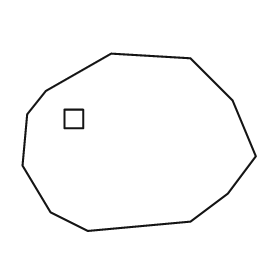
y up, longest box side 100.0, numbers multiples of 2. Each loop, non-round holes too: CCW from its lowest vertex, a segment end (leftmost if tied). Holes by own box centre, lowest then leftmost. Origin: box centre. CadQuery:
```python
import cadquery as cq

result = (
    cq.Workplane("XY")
    .moveTo(-22.0, -38.0)
    .lineTo(22.0, -34.0)
    .lineTo(38.0, -22.0)
    .lineTo(50.0, -6.0)
    .lineTo(40.0, 18.0)
    .lineTo(22.0, 36.0)
    .lineTo(-12.0, 38.0)
    .lineTo(-40.0, 22.0)
    .lineTo(-48.0, 12.0)
    .lineTo(-50.0, -10.0)
    .lineTo(-38.0, -30.0)
    .close()
    .moveTo(-32.0, 6.0)
    .lineTo(-24.0, 6.0)
    .lineTo(-24.0, 14.0)
    .lineTo(-32.0, 14.0)
    .close()
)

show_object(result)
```